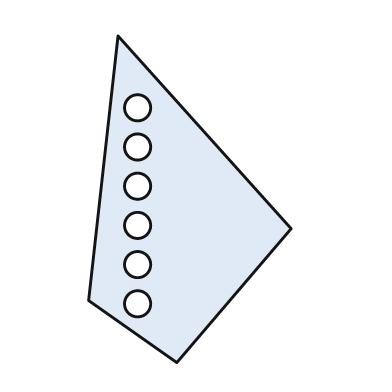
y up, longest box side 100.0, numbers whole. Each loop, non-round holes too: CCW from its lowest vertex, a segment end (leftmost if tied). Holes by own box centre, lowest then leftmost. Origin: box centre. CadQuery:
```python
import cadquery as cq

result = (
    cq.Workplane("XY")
    .moveTo(-4.0, -50.0)
    .lineTo(31.0, -9.0)
    .lineTo(-22.0, 50.0)
    .lineTo(-31.0, -31.0)
    .close()
    .moveTo(-16.0, -32.0)
    .circle(4.0)
    .moveTo(-16.0, -20.0)
    .circle(4.0)
    .moveTo(-16.0, -8.0)
    .circle(4.0)
    .moveTo(-16.0, 4.0)
    .circle(4.0)
    .moveTo(-16.0, 16.0)
    .circle(4.0)
    .moveTo(-16.0, 28.0)
    .circle(4.0)
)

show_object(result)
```